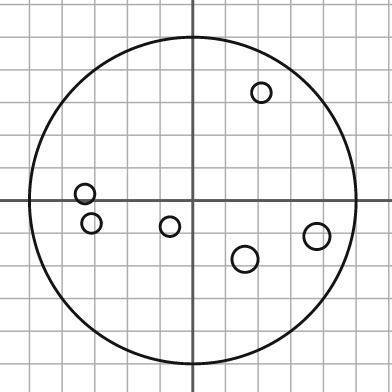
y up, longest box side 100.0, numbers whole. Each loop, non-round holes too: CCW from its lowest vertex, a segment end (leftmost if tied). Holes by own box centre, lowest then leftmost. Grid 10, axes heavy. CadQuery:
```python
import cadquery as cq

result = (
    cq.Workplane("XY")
    .moveTo(0.0, 0.0)
    .circle(50.0)
    .moveTo(16.0, -18.0)
    .circle(4.0)
    .moveTo(38.0, -11.0)
    .circle(4.0)
    .moveTo(-7.0, -8.0)
    .circle(3.0)
    .moveTo(-31.0, -7.0)
    .circle(3.0)
    .moveTo(-33.0, 2.0)
    .circle(3.0)
    .moveTo(21.0, 33.0)
    .circle(3.0)
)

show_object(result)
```